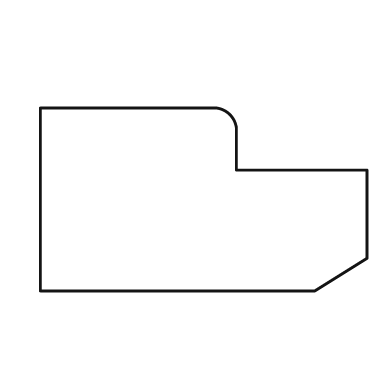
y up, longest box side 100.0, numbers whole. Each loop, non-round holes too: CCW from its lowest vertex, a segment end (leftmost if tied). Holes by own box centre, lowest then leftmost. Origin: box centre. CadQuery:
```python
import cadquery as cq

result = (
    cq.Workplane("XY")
    .moveTo(-50.0, -28.0)
    .lineTo(34.0, -28.0)
    .lineTo(50.0, -18.0)
    .lineTo(50.0, 9.0)
    .lineTo(10.0, 9.0)
    .lineTo(10.0, 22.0)
    .threePointArc((8.0, 26.0), (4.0, 28.0))
    .lineTo(-50.0, 28.0)
    .close()
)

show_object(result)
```